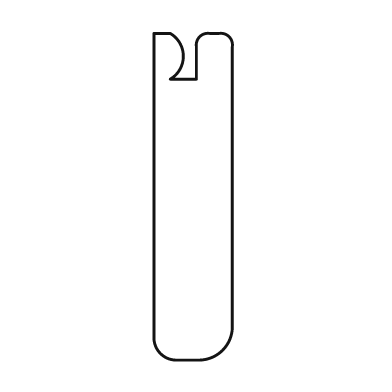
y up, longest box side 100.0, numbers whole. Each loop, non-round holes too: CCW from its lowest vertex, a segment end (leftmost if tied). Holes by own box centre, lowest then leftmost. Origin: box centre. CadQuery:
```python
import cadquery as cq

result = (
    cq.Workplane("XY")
    .moveTo(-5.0, -50.0)
    .lineTo(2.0, -50.0)
    .threePointArc((9.0, -47.0), (12.0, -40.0))
    .lineTo(12.0, 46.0)
    .threePointArc((11.0, 49.0), (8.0, 50.0))
    .lineTo(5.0, 50.0)
    .threePointArc((2.0, 49.0), (1.0, 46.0))
    .lineTo(1.0, 36.0)
    .lineTo(-7.0, 36.0)
    .threePointArc((-3.0, 43.0), (-7.0, 50.0))
    .lineTo(-12.0, 50.0)
    .lineTo(-12.0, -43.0)
    .threePointArc((-10.0, -48.0), (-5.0, -50.0))
    .close()
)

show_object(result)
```